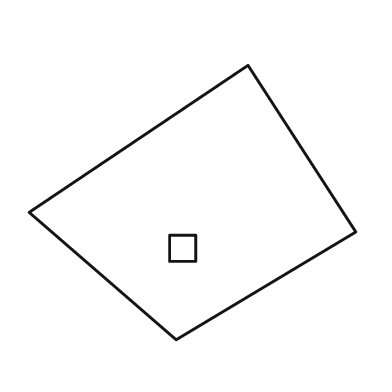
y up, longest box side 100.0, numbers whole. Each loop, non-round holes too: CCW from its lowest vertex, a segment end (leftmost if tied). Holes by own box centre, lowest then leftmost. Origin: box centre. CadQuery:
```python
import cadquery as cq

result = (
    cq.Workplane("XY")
    .moveTo(-5.0, -42.0)
    .lineTo(50.0, -9.0)
    .lineTo(17.0, 42.0)
    .lineTo(-50.0, -3.0)
    .close()
    .moveTo(-7.0, -18.0)
    .lineTo(1.0, -18.0)
    .lineTo(1.0, -10.0)
    .lineTo(-7.0, -10.0)
    .close()
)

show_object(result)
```